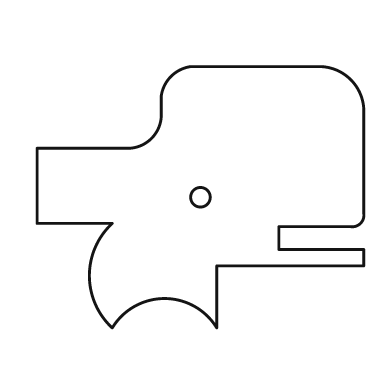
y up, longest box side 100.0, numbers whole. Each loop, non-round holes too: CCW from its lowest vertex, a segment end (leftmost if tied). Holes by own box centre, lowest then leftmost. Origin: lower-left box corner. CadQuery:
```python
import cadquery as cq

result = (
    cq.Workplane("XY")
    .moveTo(23.0, 0.0)
    .threePointArc((39.0, 9.0), (55.0, 0.0))
    .lineTo(55.0, 19.0)
    .lineTo(100.0, 19.0)
    .lineTo(100.0, 24.0)
    .lineTo(74.0, 24.0)
    .lineTo(74.0, 31.0)
    .lineTo(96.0, 31.0)
    .threePointArc((99.0, 32.0), (100.0, 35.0))
    .lineTo(100.0, 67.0)
    .threePointArc((96.0, 76.0), (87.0, 80.0))
    .lineTo(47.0, 80.0)
    .threePointArc((41.0, 77.0), (38.0, 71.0))
    .lineTo(38.0, 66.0)
    .threePointArc((35.0, 58.0), (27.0, 55.0))
    .lineTo(0.0, 55.0)
    .lineTo(0.0, 32.0)
    .lineTo(23.0, 32.0)
    .threePointArc((16.0, 16.0), (23.0, 0.0))
    .close()
    .moveTo(50.0, 40.0)
    .circle(3.0)
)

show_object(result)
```